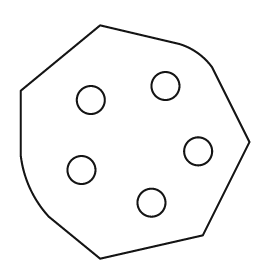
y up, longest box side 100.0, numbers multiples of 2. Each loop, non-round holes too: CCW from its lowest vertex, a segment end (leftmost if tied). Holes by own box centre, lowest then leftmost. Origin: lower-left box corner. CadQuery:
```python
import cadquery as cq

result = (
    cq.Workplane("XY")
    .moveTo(34.0, 0.0)
    .lineTo(78.0, 10.0)
    .lineTo(98.0, 50.0)
    .lineTo(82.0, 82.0)
    .threePointArc((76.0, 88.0), (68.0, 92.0))
    .lineTo(34.0, 100.0)
    .lineTo(0.0, 72.0)
    .lineTo(0.0, 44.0)
    .threePointArc((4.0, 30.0), (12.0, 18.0))
    .close()
    .moveTo(56.0, 24.0)
    .circle(6.0)
    .moveTo(26.0, 38.0)
    .circle(6.0)
    .moveTo(76.0, 46.0)
    .circle(6.0)
    .moveTo(30.0, 68.0)
    .circle(6.0)
    .moveTo(62.0, 74.0)
    .circle(6.0)
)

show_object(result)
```